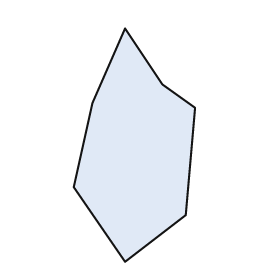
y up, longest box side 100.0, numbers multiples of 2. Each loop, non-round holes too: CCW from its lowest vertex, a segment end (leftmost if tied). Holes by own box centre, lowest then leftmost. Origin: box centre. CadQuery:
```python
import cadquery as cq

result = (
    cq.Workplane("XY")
    .moveTo(-4.0, -50.0)
    .lineTo(22.0, -30.0)
    .lineTo(26.0, 16.0)
    .lineTo(12.0, 26.0)
    .lineTo(-4.0, 50.0)
    .lineTo(-18.0, 18.0)
    .lineTo(-26.0, -18.0)
    .close()
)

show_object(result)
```